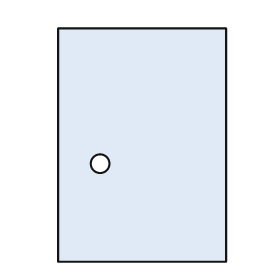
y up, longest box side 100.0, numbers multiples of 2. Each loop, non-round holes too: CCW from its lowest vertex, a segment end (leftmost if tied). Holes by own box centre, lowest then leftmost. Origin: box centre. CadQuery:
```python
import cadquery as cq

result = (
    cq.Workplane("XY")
    .moveTo(-36.0, -50.0)
    .lineTo(36.0, -50.0)
    .lineTo(36.0, 50.0)
    .lineTo(-36.0, 50.0)
    .close()
    .moveTo(-18.0, -8.0)
    .circle(4.0)
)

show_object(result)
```